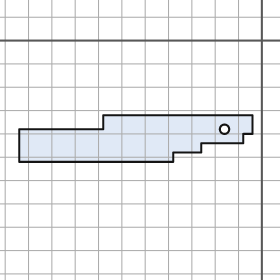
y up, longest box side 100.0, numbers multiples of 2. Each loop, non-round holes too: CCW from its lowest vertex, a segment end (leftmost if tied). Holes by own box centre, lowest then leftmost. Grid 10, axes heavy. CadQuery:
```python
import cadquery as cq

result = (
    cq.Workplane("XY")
    .moveTo(-104.0, -52.0)
    .lineTo(-38.0, -52.0)
    .lineTo(-38.0, -48.0)
    .lineTo(-26.0, -48.0)
    .lineTo(-26.0, -44.0)
    .lineTo(-8.0, -44.0)
    .lineTo(-8.0, -40.0)
    .lineTo(-4.0, -40.0)
    .lineTo(-4.0, -32.0)
    .lineTo(-68.0, -32.0)
    .lineTo(-68.0, -38.0)
    .lineTo(-104.0, -38.0)
    .close()
    .moveTo(-16.0, -38.0)
    .circle(2.0)
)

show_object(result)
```